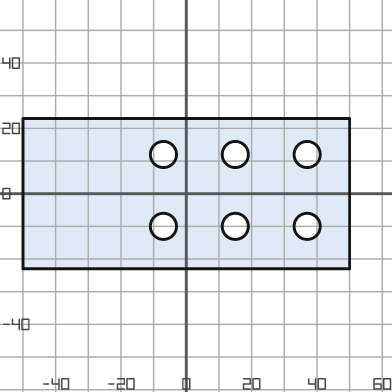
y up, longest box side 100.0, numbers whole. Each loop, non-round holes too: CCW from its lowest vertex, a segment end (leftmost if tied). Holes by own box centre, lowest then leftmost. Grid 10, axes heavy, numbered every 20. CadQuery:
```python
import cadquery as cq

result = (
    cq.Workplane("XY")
    .moveTo(-50.0, -23.0)
    .lineTo(50.0, -23.0)
    .lineTo(50.0, 23.0)
    .lineTo(-50.0, 23.0)
    .close()
    .moveTo(-7.0, -10.0)
    .circle(4.0)
    .moveTo(15.0, -10.0)
    .circle(4.0)
    .moveTo(37.0, -10.0)
    .circle(4.0)
    .moveTo(-7.0, 12.0)
    .circle(4.0)
    .moveTo(15.0, 12.0)
    .circle(4.0)
    .moveTo(37.0, 12.0)
    .circle(4.0)
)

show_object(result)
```